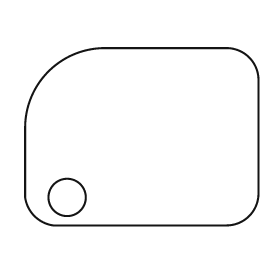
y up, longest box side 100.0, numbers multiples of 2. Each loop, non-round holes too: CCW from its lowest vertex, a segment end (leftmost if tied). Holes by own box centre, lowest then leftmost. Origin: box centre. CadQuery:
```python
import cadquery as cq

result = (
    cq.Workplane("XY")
    .moveTo(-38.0, -38.0)
    .lineTo(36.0, -38.0)
    .threePointArc((46.0, -34.0), (50.0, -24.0))
    .lineTo(50.0, 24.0)
    .threePointArc((46.0, 34.0), (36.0, 38.0))
    .lineTo(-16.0, 38.0)
    .threePointArc((-40.0, 28.0), (-50.0, 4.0))
    .lineTo(-50.0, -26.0)
    .threePointArc((-46.0, -34.0), (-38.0, -38.0))
    .close()
    .moveTo(-32.0, -26.0)
    .circle(8.0)
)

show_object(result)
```